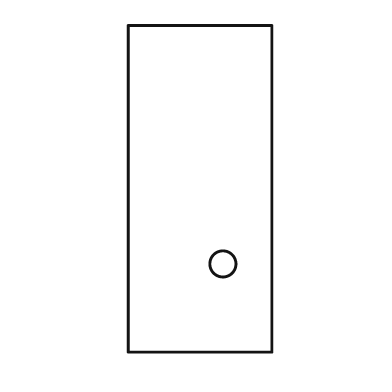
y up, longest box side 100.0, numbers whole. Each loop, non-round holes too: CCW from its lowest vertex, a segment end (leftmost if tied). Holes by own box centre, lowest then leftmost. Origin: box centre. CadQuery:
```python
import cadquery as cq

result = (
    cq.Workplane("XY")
    .moveTo(-22.0, -50.0)
    .lineTo(22.0, -50.0)
    .lineTo(22.0, 50.0)
    .lineTo(-22.0, 50.0)
    .close()
    .moveTo(7.0, -23.0)
    .circle(4.0)
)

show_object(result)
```